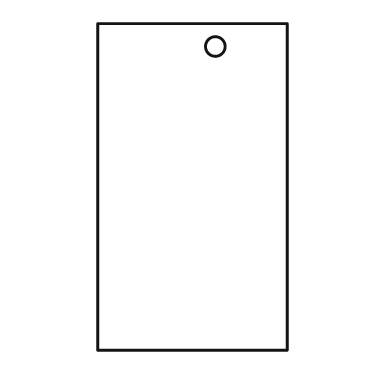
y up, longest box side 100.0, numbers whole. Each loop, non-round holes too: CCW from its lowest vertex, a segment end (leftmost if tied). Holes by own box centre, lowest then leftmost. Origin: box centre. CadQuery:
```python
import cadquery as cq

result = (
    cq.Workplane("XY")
    .moveTo(-29.0, -50.0)
    .lineTo(29.0, -50.0)
    .lineTo(29.0, 50.0)
    .lineTo(-29.0, 50.0)
    .close()
    .moveTo(7.0, 43.0)
    .circle(3.0)
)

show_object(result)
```